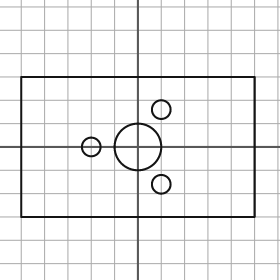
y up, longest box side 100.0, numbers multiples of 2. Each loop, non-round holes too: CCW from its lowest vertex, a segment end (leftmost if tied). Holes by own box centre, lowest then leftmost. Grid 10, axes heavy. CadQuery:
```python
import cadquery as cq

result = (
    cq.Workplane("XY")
    .moveTo(-50.0, -30.0)
    .lineTo(50.0, -30.0)
    .lineTo(50.0, 30.0)
    .lineTo(-50.0, 30.0)
    .close()
    .moveTo(10.0, -16.0)
    .circle(4.0)
    .moveTo(-20.0, 0.0)
    .circle(4.0)
    .moveTo(0.0, 0.0)
    .circle(10.0)
    .moveTo(10.0, 16.0)
    .circle(4.0)
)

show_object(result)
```